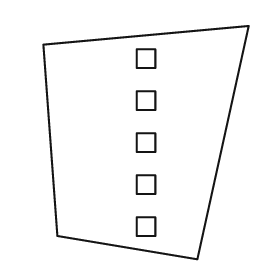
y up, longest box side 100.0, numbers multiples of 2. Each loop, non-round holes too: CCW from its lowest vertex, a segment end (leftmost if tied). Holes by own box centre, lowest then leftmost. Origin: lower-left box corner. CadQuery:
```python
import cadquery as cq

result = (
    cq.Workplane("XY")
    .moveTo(66.0, 0.0)
    .lineTo(88.0, 100.0)
    .lineTo(0.0, 92.0)
    .lineTo(6.0, 10.0)
    .close()
    .moveTo(40.0, 10.0)
    .lineTo(48.0, 10.0)
    .lineTo(48.0, 18.0)
    .lineTo(40.0, 18.0)
    .close()
    .moveTo(40.0, 28.0)
    .lineTo(48.0, 28.0)
    .lineTo(48.0, 36.0)
    .lineTo(40.0, 36.0)
    .close()
    .moveTo(40.0, 46.0)
    .lineTo(48.0, 46.0)
    .lineTo(48.0, 54.0)
    .lineTo(40.0, 54.0)
    .close()
    .moveTo(40.0, 64.0)
    .lineTo(48.0, 64.0)
    .lineTo(48.0, 72.0)
    .lineTo(40.0, 72.0)
    .close()
    .moveTo(40.0, 82.0)
    .lineTo(48.0, 82.0)
    .lineTo(48.0, 90.0)
    .lineTo(40.0, 90.0)
    .close()
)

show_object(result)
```